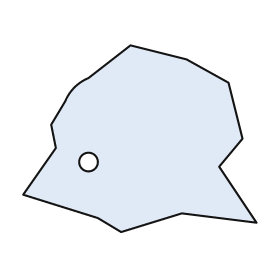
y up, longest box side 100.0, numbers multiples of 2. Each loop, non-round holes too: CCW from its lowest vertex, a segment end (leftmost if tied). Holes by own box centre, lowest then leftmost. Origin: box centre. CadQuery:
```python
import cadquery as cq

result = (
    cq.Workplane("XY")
    .moveTo(-8.0, -40.0)
    .lineTo(18.0, -32.0)
    .lineTo(50.0, -36.0)
    .lineTo(34.0, -12.0)
    .lineTo(44.0, 0.0)
    .lineTo(38.0, 24.0)
    .lineTo(20.0, 34.0)
    .lineTo(-4.0, 40.0)
    .lineTo(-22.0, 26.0)
    .threePointArc((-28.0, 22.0), (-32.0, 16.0))
    .lineTo(-38.0, 6.0)
    .lineTo(-36.0, -4.0)
    .lineTo(-50.0, -24.0)
    .lineTo(-18.0, -34.0)
    .close()
    .moveTo(-22.0, -10.0)
    .circle(4.0)
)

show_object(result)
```